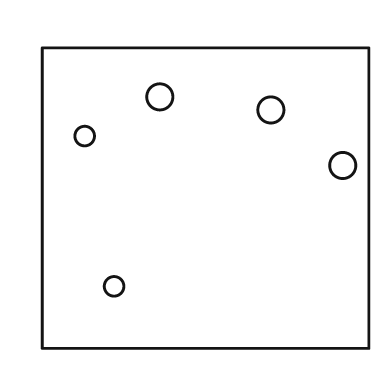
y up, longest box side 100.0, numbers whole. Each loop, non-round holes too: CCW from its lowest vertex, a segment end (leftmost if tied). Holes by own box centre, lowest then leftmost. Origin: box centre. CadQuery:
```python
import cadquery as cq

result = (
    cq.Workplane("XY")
    .moveTo(-50.0, -46.0)
    .lineTo(50.0, -46.0)
    .lineTo(50.0, 46.0)
    .lineTo(-50.0, 46.0)
    .close()
    .moveTo(-28.0, -27.0)
    .circle(3.0)
    .moveTo(42.0, 10.0)
    .circle(4.0)
    .moveTo(-37.0, 19.0)
    .circle(3.0)
    .moveTo(20.0, 27.0)
    .circle(4.0)
    .moveTo(-14.0, 31.0)
    .circle(4.0)
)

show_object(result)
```